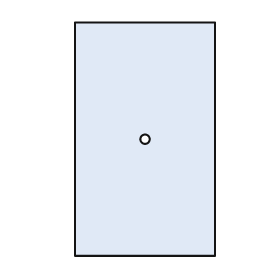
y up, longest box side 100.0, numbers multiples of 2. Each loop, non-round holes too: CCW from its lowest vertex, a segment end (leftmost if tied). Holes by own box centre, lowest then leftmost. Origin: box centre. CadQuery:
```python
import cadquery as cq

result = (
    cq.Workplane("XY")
    .moveTo(-30.0, -50.0)
    .lineTo(30.0, -50.0)
    .lineTo(30.0, 50.0)
    .lineTo(-30.0, 50.0)
    .close()
    .moveTo(0.0, 0.0)
    .circle(2.0)
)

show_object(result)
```